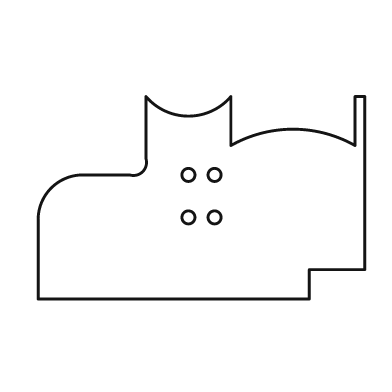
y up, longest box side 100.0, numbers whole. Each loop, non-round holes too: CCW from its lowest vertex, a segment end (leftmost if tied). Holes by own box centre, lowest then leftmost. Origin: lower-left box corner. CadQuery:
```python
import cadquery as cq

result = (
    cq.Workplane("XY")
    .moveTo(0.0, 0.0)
    .lineTo(83.0, 0.0)
    .lineTo(83.0, 9.0)
    .lineTo(100.0, 9.0)
    .lineTo(100.0, 62.0)
    .lineTo(97.0, 62.0)
    .lineTo(97.0, 47.0)
    .threePointArc((78.0, 52.0), (59.0, 47.0))
    .lineTo(59.0, 62.0)
    .threePointArc((46.0, 56.0), (33.0, 62.0))
    .lineTo(33.0, 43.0)
    .threePointArc((32.0, 39.0), (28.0, 38.0))
    .lineTo(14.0, 38.0)
    .threePointArc((4.0, 34.0), (0.0, 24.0))
    .close()
    .moveTo(46.0, 25.0)
    .circle(2.0)
    .moveTo(54.0, 25.0)
    .circle(2.0)
    .moveTo(46.0, 38.0)
    .circle(2.0)
    .moveTo(54.0, 38.0)
    .circle(2.0)
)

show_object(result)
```